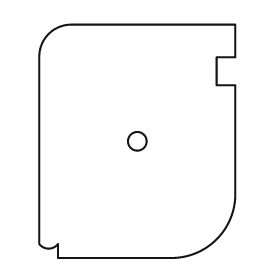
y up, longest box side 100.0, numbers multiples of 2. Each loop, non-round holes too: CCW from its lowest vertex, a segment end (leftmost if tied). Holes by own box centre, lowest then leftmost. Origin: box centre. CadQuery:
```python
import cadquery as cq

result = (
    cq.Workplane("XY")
    .moveTo(-34.0, -50.0)
    .lineTo(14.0, -50.0)
    .threePointArc((34.0, -42.0), (42.0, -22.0))
    .lineTo(42.0, 24.0)
    .lineTo(34.0, 24.0)
    .lineTo(34.0, 36.0)
    .lineTo(42.0, 36.0)
    .lineTo(42.0, 50.0)
    .lineTo(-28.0, 50.0)
    .threePointArc((-38.0, 46.0), (-42.0, 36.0))
    .lineTo(-42.0, -44.0)
    .threePointArc((-38.0, -46.0), (-34.0, -44.0))
    .close()
    .moveTo(0.0, 0.0)
    .circle(4.0)
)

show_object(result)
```